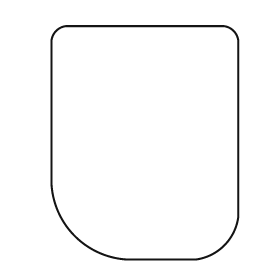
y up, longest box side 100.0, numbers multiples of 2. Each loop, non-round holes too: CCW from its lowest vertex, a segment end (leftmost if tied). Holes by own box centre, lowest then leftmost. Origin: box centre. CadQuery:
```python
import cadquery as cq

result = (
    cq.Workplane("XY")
    .moveTo(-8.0, -50.0)
    .lineTo(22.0, -50.0)
    .threePointArc((34.0, -44.0), (40.0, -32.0))
    .lineTo(40.0, 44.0)
    .threePointArc((38.0, 48.0), (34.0, 50.0))
    .lineTo(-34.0, 50.0)
    .threePointArc((-38.0, 48.0), (-40.0, 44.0))
    .lineTo(-40.0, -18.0)
    .threePointArc((-30.0, -40.0), (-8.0, -50.0))
    .close()
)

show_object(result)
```